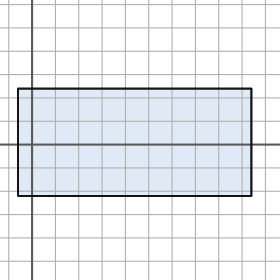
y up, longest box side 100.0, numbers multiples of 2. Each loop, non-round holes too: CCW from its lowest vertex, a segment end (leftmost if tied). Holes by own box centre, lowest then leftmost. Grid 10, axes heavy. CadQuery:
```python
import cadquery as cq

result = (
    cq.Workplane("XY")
    .moveTo(-6.0, -22.0)
    .lineTo(94.0, -22.0)
    .lineTo(94.0, 24.0)
    .lineTo(-6.0, 24.0)
    .close()
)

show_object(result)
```